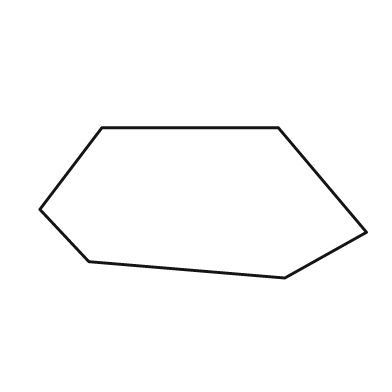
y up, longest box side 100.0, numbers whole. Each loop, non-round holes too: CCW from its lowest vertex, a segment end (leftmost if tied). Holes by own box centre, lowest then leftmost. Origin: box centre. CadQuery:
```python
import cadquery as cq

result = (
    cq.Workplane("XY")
    .moveTo(25.0, -23.0)
    .lineTo(50.0, -9.0)
    .lineTo(23.0, 23.0)
    .lineTo(-31.0, 23.0)
    .lineTo(-50.0, -2.0)
    .lineTo(-35.0, -18.0)
    .close()
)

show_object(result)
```